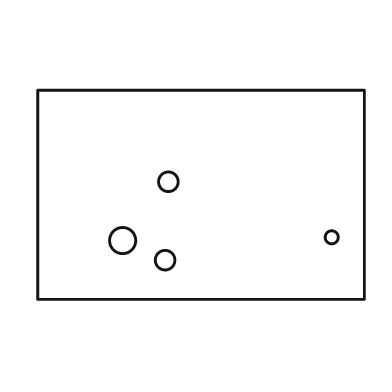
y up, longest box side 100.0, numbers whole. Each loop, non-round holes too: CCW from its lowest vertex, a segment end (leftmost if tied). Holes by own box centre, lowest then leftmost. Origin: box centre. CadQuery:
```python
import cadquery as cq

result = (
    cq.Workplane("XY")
    .moveTo(-50.0, -32.0)
    .lineTo(50.0, -32.0)
    .lineTo(50.0, 32.0)
    .lineTo(-50.0, 32.0)
    .close()
    .moveTo(-11.0, -20.0)
    .circle(3.0)
    .moveTo(-24.0, -14.0)
    .circle(4.0)
    .moveTo(40.0, -13.0)
    .circle(2.0)
    .moveTo(-10.0, 4.0)
    .circle(3.0)
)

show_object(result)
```